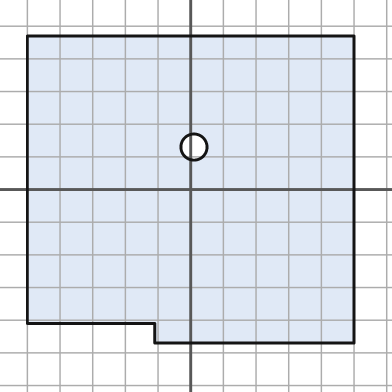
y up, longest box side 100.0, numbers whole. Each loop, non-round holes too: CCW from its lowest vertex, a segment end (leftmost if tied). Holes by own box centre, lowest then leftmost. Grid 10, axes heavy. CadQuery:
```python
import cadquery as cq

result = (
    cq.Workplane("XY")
    .moveTo(-11.0, -47.0)
    .lineTo(50.0, -47.0)
    .lineTo(50.0, 47.0)
    .lineTo(-50.0, 47.0)
    .lineTo(-50.0, -41.0)
    .lineTo(-11.0, -41.0)
    .close()
    .moveTo(1.0, 13.0)
    .circle(4.0)
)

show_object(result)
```